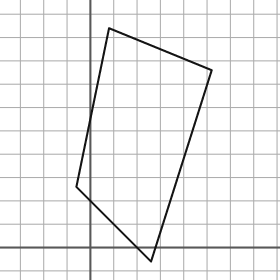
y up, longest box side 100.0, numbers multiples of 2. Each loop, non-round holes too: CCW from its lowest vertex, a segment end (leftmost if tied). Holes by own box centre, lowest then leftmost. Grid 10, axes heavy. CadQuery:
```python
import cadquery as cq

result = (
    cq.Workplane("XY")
    .moveTo(26.0, -6.0)
    .lineTo(52.0, 76.0)
    .lineTo(8.0, 94.0)
    .lineTo(-6.0, 26.0)
    .close()
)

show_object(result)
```